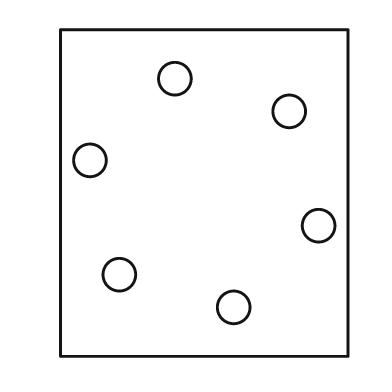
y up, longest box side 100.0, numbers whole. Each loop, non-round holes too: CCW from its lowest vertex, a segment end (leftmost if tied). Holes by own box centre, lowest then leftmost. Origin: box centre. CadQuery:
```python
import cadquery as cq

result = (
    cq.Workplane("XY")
    .moveTo(-44.0, -50.0)
    .lineTo(44.0, -50.0)
    .lineTo(44.0, 50.0)
    .lineTo(-44.0, 50.0)
    .close()
    .moveTo(9.0, -35.0)
    .circle(5.0)
    .moveTo(-26.0, -25.0)
    .circle(5.0)
    .moveTo(35.0, -10.0)
    .circle(5.0)
    .moveTo(-35.0, 10.0)
    .circle(5.0)
    .moveTo(26.0, 25.0)
    .circle(5.0)
    .moveTo(-9.0, 35.0)
    .circle(5.0)
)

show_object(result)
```